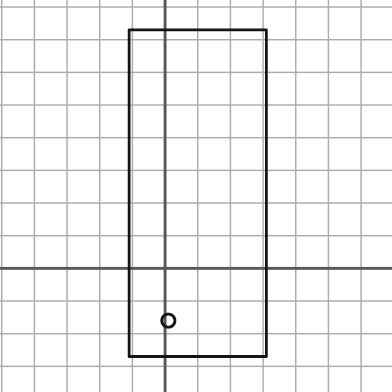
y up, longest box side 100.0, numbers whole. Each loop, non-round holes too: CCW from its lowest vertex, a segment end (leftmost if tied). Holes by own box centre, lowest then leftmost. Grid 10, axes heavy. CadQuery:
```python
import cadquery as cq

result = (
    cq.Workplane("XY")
    .moveTo(-11.0, -27.0)
    .lineTo(31.0, -27.0)
    .lineTo(31.0, 73.0)
    .lineTo(-11.0, 73.0)
    .close()
    .moveTo(1.0, -16.0)
    .circle(2.0)
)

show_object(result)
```